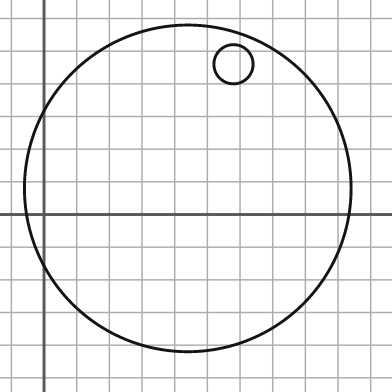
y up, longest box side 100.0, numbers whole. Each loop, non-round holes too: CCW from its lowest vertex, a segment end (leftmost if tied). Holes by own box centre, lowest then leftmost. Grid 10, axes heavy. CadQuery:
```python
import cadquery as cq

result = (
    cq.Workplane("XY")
    .moveTo(44.0, 8.0)
    .circle(50.0)
    .moveTo(58.0, 46.0)
    .circle(6.0)
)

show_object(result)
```